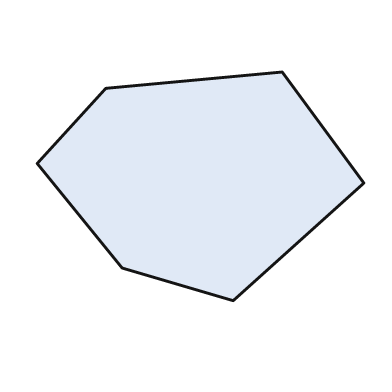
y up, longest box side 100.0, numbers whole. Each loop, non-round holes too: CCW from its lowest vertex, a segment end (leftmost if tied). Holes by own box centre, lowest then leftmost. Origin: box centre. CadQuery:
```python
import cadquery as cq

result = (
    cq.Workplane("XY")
    .moveTo(10.0, -35.0)
    .lineTo(50.0, 1.0)
    .lineTo(25.0, 35.0)
    .lineTo(-29.0, 30.0)
    .lineTo(-50.0, 7.0)
    .lineTo(-24.0, -25.0)
    .close()
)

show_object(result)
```